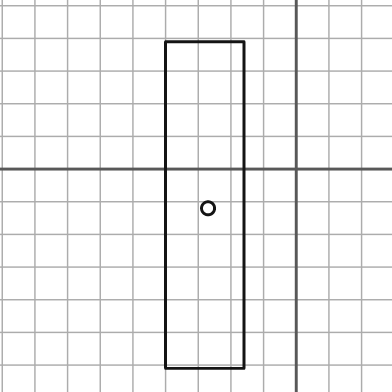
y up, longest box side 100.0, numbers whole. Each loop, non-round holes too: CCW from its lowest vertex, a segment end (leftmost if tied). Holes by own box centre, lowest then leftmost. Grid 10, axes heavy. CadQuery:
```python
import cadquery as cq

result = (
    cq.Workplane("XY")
    .moveTo(-40.0, -61.0)
    .lineTo(-16.0, -61.0)
    .lineTo(-16.0, 39.0)
    .lineTo(-40.0, 39.0)
    .close()
    .moveTo(-27.0, -12.0)
    .circle(2.0)
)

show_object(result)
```